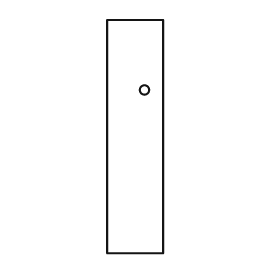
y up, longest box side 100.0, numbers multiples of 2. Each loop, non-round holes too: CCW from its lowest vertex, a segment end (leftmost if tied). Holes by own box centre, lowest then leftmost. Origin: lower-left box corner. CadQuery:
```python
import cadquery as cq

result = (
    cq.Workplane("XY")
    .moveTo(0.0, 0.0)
    .lineTo(24.0, 0.0)
    .lineTo(24.0, 100.0)
    .lineTo(0.0, 100.0)
    .close()
    .moveTo(16.0, 70.0)
    .circle(2.0)
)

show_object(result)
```